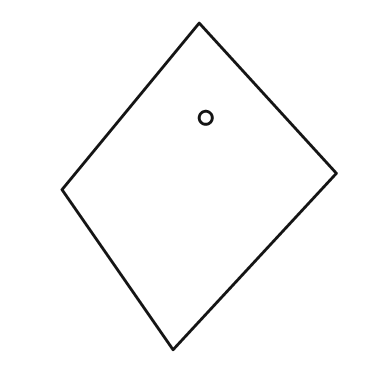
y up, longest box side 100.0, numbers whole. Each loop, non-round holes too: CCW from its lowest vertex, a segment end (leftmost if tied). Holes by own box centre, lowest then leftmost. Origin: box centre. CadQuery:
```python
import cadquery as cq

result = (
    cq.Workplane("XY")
    .moveTo(-8.0, -50.0)
    .lineTo(42.0, 4.0)
    .lineTo(0.0, 50.0)
    .lineTo(-42.0, -1.0)
    .close()
    .moveTo(2.0, 21.0)
    .circle(2.0)
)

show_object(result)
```